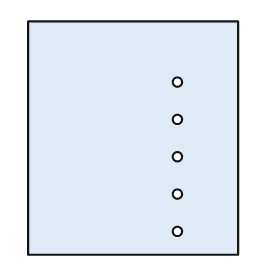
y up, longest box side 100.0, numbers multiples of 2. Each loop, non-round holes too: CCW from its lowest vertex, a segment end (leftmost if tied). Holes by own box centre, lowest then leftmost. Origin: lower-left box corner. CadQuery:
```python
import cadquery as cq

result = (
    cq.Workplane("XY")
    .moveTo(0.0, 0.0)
    .lineTo(90.0, 0.0)
    .lineTo(90.0, 100.0)
    .lineTo(0.0, 100.0)
    .close()
    .moveTo(64.0, 10.0)
    .circle(2.0)
    .moveTo(64.0, 26.0)
    .circle(2.0)
    .moveTo(64.0, 42.0)
    .circle(2.0)
    .moveTo(64.0, 58.0)
    .circle(2.0)
    .moveTo(64.0, 74.0)
    .circle(2.0)
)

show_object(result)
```